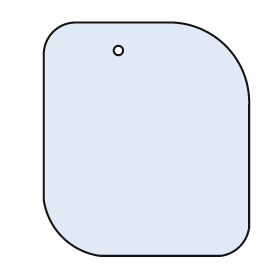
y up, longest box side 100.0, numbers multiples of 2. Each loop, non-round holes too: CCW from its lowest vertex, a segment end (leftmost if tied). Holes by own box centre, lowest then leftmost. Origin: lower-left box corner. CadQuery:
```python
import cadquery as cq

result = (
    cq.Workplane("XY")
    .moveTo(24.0, 0.0)
    .lineTo(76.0, 0.0)
    .threePointArc((84.0, 4.0), (88.0, 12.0))
    .lineTo(88.0, 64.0)
    .threePointArc((78.0, 90.0), (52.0, 100.0))
    .lineTo(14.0, 100.0)
    .threePointArc((4.0, 96.0), (0.0, 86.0))
    .lineTo(0.0, 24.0)
    .threePointArc((8.0, 8.0), (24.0, 0.0))
    .close()
    .moveTo(32.0, 88.0)
    .circle(2.0)
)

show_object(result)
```